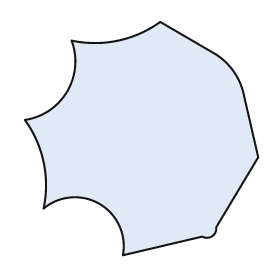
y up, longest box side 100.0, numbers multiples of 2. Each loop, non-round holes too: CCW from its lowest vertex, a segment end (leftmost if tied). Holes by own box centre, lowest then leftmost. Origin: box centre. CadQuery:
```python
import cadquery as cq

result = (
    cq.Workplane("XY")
    .moveTo(-8.0, -50.0)
    .lineTo(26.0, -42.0)
    .threePointArc((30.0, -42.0), (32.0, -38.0))
    .lineTo(50.0, -8.0)
    .lineTo(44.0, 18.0)
    .threePointArc((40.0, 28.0), (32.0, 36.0))
    .lineTo(8.0, 50.0)
    .threePointArc((-10.0, 42.0), (-30.0, 42.0))
    .threePointArc((-32.0, 20.0), (-50.0, 8.0))
    .threePointArc((-42.0, -10.0), (-42.0, -30.0))
    .threePointArc((-18.0, -28.0), (-8.0, -50.0))
    .close()
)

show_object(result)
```